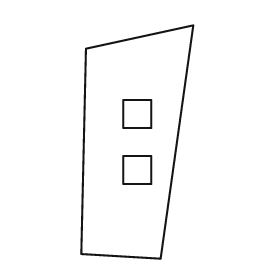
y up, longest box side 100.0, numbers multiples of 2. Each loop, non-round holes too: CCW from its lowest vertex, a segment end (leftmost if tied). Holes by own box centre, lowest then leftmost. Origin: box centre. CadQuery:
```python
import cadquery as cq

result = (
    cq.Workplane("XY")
    .moveTo(10.0, -50.0)
    .lineTo(24.0, 50.0)
    .lineTo(-22.0, 40.0)
    .lineTo(-24.0, -48.0)
    .close()
    .moveTo(-6.0, -18.0)
    .lineTo(6.0, -18.0)
    .lineTo(6.0, -6.0)
    .lineTo(-6.0, -6.0)
    .close()
    .moveTo(-6.0, 6.0)
    .lineTo(6.0, 6.0)
    .lineTo(6.0, 18.0)
    .lineTo(-6.0, 18.0)
    .close()
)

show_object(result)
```